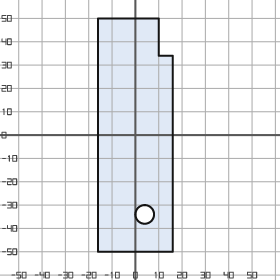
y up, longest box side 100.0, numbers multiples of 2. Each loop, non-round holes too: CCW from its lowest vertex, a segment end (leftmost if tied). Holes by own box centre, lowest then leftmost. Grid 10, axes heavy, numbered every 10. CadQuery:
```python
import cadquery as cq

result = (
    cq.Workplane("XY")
    .moveTo(-16.0, -50.0)
    .lineTo(16.0, -50.0)
    .lineTo(16.0, 34.0)
    .lineTo(10.0, 34.0)
    .lineTo(10.0, 50.0)
    .lineTo(-16.0, 50.0)
    .close()
    .moveTo(4.0, -34.0)
    .circle(4.0)
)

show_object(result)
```